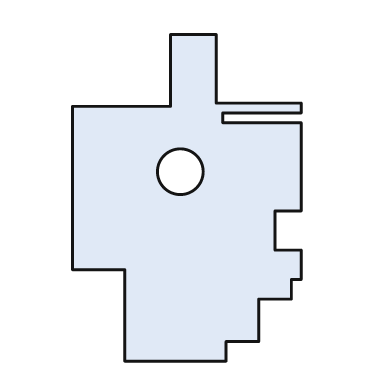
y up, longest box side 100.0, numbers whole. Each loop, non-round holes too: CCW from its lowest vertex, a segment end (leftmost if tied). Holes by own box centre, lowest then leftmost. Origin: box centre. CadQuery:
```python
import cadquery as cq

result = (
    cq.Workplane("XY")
    .moveTo(-19.0, -50.0)
    .lineTo(12.0, -50.0)
    .lineTo(12.0, -44.0)
    .lineTo(22.0, -44.0)
    .lineTo(22.0, -31.0)
    .lineTo(32.0, -31.0)
    .lineTo(32.0, -25.0)
    .lineTo(35.0, -25.0)
    .lineTo(35.0, -16.0)
    .lineTo(27.0, -16.0)
    .lineTo(27.0, -4.0)
    .lineTo(35.0, -4.0)
    .lineTo(35.0, 23.0)
    .lineTo(11.0, 23.0)
    .lineTo(11.0, 26.0)
    .lineTo(35.0, 26.0)
    .lineTo(35.0, 29.0)
    .lineTo(9.0, 29.0)
    .lineTo(9.0, 50.0)
    .lineTo(-5.0, 50.0)
    .lineTo(-5.0, 28.0)
    .lineTo(-35.0, 28.0)
    .lineTo(-35.0, -22.0)
    .lineTo(-19.0, -22.0)
    .close()
    .moveTo(-2.0, 8.0)
    .circle(7.0)
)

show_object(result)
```